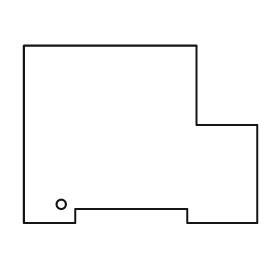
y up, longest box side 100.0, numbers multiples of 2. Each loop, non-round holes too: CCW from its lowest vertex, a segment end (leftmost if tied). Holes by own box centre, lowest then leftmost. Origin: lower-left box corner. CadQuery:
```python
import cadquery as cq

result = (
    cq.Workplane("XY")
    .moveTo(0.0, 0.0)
    .lineTo(22.0, 0.0)
    .lineTo(22.0, 6.0)
    .lineTo(70.0, 6.0)
    .lineTo(70.0, 0.0)
    .lineTo(100.0, 0.0)
    .lineTo(100.0, 42.0)
    .lineTo(74.0, 42.0)
    .lineTo(74.0, 76.0)
    .lineTo(0.0, 76.0)
    .close()
    .moveTo(16.0, 8.0)
    .circle(2.0)
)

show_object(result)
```